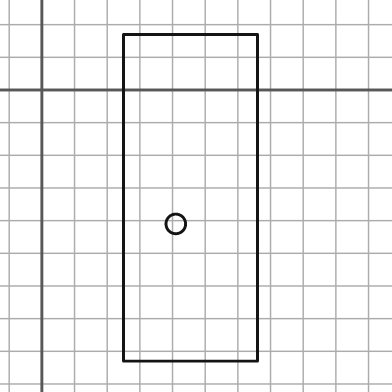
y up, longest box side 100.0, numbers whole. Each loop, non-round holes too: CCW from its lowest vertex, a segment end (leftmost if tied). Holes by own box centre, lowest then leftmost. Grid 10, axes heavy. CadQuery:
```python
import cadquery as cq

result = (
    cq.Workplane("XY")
    .moveTo(25.0, -83.0)
    .lineTo(66.0, -83.0)
    .lineTo(66.0, 17.0)
    .lineTo(25.0, 17.0)
    .close()
    .moveTo(41.0, -41.0)
    .circle(3.0)
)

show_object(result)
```